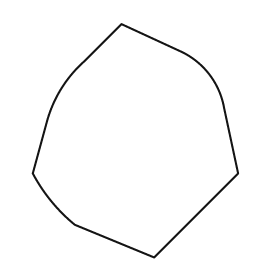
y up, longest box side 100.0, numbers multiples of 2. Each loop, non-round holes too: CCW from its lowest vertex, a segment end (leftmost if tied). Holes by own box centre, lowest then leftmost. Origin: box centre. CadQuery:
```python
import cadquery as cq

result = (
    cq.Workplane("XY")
    .moveTo(8.0, -50.0)
    .lineTo(44.0, -14.0)
    .lineTo(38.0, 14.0)
    .threePointArc((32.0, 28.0), (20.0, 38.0))
    .lineTo(-6.0, 50.0)
    .lineTo(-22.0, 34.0)
    .threePointArc((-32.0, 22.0), (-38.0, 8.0))
    .lineTo(-44.0, -14.0)
    .threePointArc((-36.0, -26.0), (-26.0, -36.0))
    .close()
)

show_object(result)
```